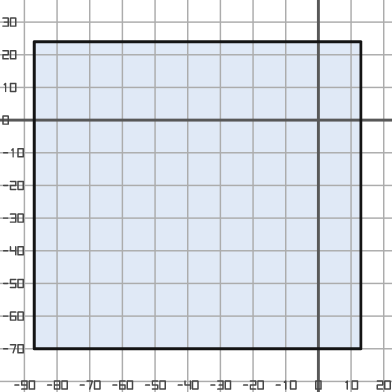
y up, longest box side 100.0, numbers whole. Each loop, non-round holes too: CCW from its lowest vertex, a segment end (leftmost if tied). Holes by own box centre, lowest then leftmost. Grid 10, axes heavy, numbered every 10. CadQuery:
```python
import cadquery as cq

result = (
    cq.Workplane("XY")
    .moveTo(-87.0, -70.0)
    .lineTo(13.0, -70.0)
    .lineTo(13.0, 24.0)
    .lineTo(-87.0, 24.0)
    .close()
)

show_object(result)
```